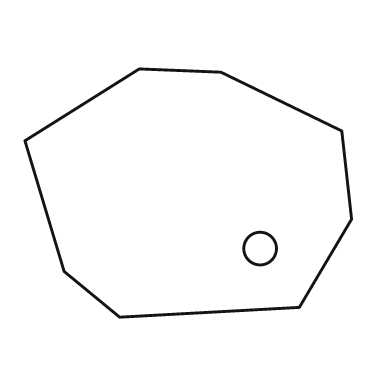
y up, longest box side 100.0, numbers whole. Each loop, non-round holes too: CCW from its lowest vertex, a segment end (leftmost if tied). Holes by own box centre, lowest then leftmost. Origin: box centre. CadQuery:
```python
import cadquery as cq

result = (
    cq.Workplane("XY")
    .moveTo(-21.0, -38.0)
    .lineTo(34.0, -35.0)
    .lineTo(50.0, -8.0)
    .lineTo(47.0, 19.0)
    .lineTo(10.0, 37.0)
    .lineTo(-15.0, 38.0)
    .lineTo(-50.0, 16.0)
    .lineTo(-38.0, -24.0)
    .close()
    .moveTo(22.0, -17.0)
    .circle(5.0)
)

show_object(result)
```